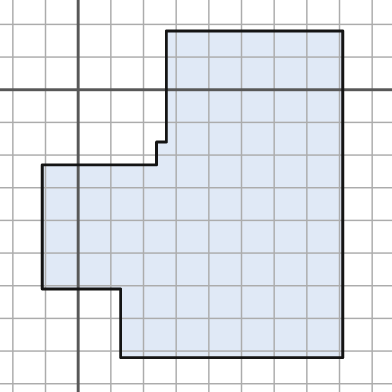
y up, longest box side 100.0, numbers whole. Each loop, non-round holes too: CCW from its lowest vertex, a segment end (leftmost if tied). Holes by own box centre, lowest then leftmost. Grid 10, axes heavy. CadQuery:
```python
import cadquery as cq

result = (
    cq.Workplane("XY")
    .moveTo(13.0, -82.0)
    .lineTo(81.0, -82.0)
    .lineTo(81.0, 18.0)
    .lineTo(27.0, 18.0)
    .lineTo(27.0, -16.0)
    .lineTo(24.0, -16.0)
    .lineTo(24.0, -23.0)
    .lineTo(-11.0, -23.0)
    .lineTo(-11.0, -61.0)
    .lineTo(13.0, -61.0)
    .close()
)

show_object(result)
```